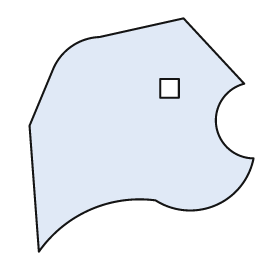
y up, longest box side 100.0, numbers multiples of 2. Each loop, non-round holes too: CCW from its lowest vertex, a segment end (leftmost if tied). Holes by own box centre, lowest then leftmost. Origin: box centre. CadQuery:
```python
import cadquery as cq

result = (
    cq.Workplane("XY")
    .moveTo(-44.0, -50.0)
    .threePointArc((-22.0, -32.0), (6.0, -28.0))
    .threePointArc((32.0, -30.0), (48.0, -10.0))
    .threePointArc((32.0, 4.0), (44.0, 22.0))
    .lineTo(18.0, 50.0)
    .lineTo(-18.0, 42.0)
    .threePointArc((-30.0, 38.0), (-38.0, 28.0))
    .lineTo(-48.0, 4.0)
    .close()
    .moveTo(8.0, 16.0)
    .lineTo(16.0, 16.0)
    .lineTo(16.0, 24.0)
    .lineTo(8.0, 24.0)
    .close()
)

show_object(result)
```